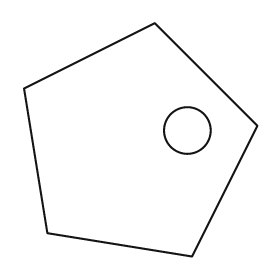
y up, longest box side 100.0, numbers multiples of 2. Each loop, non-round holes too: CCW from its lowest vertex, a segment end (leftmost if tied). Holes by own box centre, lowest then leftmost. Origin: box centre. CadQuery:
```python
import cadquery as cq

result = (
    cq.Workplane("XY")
    .moveTo(22.0, -50.0)
    .lineTo(50.0, 6.0)
    .lineTo(6.0, 50.0)
    .lineTo(-50.0, 22.0)
    .lineTo(-40.0, -40.0)
    .close()
    .moveTo(20.0, 4.0)
    .circle(10.0)
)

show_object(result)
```